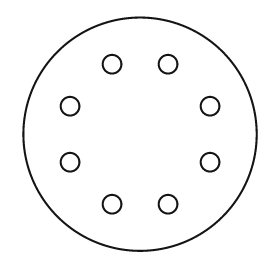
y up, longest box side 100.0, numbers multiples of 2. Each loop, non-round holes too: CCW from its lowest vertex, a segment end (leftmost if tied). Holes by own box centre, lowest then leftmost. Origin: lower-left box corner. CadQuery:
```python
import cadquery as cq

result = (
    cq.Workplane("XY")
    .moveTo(50.0, 50.0)
    .circle(50.0)
    .moveTo(38.0, 20.0)
    .circle(4.0)
    .moveTo(62.0, 20.0)
    .circle(4.0)
    .moveTo(20.0, 38.0)
    .circle(4.0)
    .moveTo(80.0, 38.0)
    .circle(4.0)
    .moveTo(20.0, 62.0)
    .circle(4.0)
    .moveTo(80.0, 62.0)
    .circle(4.0)
    .moveTo(38.0, 80.0)
    .circle(4.0)
    .moveTo(62.0, 80.0)
    .circle(4.0)
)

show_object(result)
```